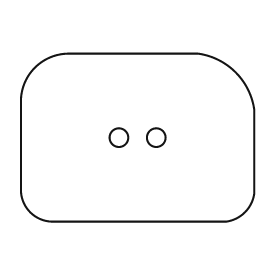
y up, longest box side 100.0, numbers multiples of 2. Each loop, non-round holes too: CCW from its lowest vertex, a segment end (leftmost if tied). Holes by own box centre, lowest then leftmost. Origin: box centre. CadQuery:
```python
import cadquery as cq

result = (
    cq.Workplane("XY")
    .moveTo(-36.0, -36.0)
    .lineTo(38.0, -36.0)
    .threePointArc((46.0, -32.0), (50.0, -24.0))
    .lineTo(50.0, 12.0)
    .threePointArc((42.0, 28.0), (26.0, 36.0))
    .lineTo(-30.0, 36.0)
    .threePointArc((-44.0, 30.0), (-50.0, 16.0))
    .lineTo(-50.0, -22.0)
    .threePointArc((-46.0, -32.0), (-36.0, -36.0))
    .close()
    .moveTo(-8.0, 0.0)
    .circle(4.0)
    .moveTo(8.0, 0.0)
    .circle(4.0)
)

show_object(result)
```